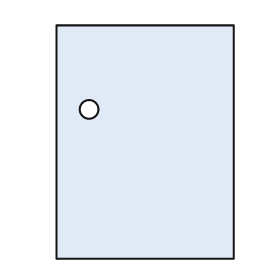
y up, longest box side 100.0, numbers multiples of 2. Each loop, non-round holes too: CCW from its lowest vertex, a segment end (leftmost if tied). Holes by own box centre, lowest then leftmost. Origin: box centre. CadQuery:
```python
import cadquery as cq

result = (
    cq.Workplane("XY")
    .moveTo(-38.0, -50.0)
    .lineTo(38.0, -50.0)
    .lineTo(38.0, 50.0)
    .lineTo(-38.0, 50.0)
    .close()
    .moveTo(-24.0, 14.0)
    .circle(4.0)
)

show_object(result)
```